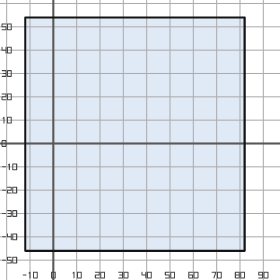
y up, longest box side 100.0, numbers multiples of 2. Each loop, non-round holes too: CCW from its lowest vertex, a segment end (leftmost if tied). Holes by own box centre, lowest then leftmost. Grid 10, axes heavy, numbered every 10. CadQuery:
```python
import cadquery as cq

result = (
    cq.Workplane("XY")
    .moveTo(-12.0, -46.0)
    .lineTo(82.0, -46.0)
    .lineTo(82.0, 54.0)
    .lineTo(-12.0, 54.0)
    .close()
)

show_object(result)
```